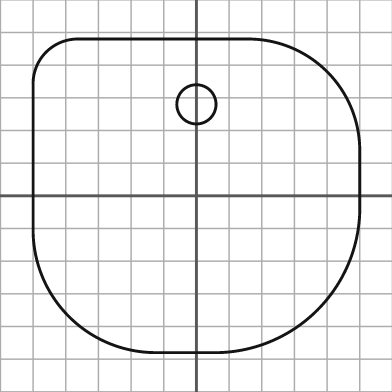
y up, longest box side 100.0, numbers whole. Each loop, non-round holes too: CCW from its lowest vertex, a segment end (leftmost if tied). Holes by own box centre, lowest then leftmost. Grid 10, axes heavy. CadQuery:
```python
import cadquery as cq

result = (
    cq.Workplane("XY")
    .moveTo(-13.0, -48.0)
    .lineTo(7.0, -48.0)
    .threePointArc((37.0, -35.0), (50.0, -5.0))
    .lineTo(50.0, 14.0)
    .threePointArc((40.0, 38.0), (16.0, 48.0))
    .lineTo(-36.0, 48.0)
    .threePointArc((-46.0, 44.0), (-50.0, 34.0))
    .lineTo(-50.0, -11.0)
    .threePointArc((-39.0, -37.0), (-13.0, -48.0))
    .close()
    .moveTo(0.0, 28.0)
    .circle(6.0)
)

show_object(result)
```